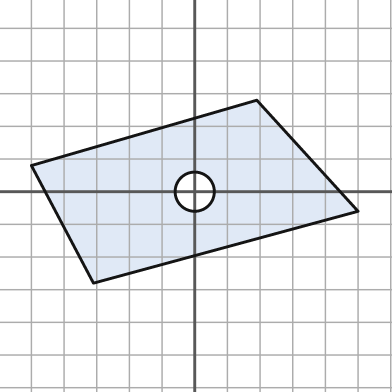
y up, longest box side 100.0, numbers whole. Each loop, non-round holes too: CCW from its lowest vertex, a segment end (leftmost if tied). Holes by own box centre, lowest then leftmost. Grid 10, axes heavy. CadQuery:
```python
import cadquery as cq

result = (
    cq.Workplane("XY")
    .moveTo(-31.0, -28.0)
    .lineTo(50.0, -6.0)
    .lineTo(19.0, 28.0)
    .lineTo(-50.0, 8.0)
    .close()
    .moveTo(0.0, 0.0)
    .circle(6.0)
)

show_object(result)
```